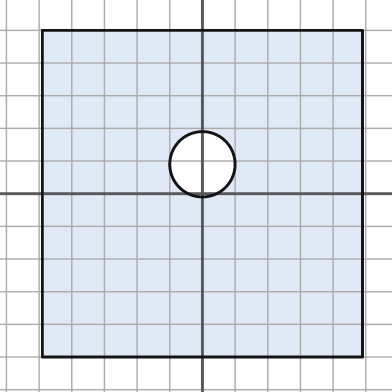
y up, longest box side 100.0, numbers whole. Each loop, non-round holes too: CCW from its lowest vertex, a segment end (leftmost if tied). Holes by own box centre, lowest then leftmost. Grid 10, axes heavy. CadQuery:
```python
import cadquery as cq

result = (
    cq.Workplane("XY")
    .moveTo(-49.0, -50.0)
    .lineTo(49.0, -50.0)
    .lineTo(49.0, 50.0)
    .lineTo(-49.0, 50.0)
    .close()
    .moveTo(0.0, 9.0)
    .circle(10.0)
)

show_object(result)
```